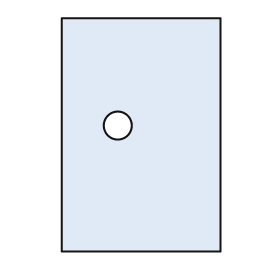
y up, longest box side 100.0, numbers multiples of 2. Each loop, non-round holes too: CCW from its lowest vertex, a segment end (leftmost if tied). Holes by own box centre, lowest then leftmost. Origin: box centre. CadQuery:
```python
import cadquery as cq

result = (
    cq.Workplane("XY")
    .moveTo(-34.0, -50.0)
    .lineTo(34.0, -50.0)
    .lineTo(34.0, 50.0)
    .lineTo(-34.0, 50.0)
    .close()
    .moveTo(-10.0, 4.0)
    .circle(6.0)
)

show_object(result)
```